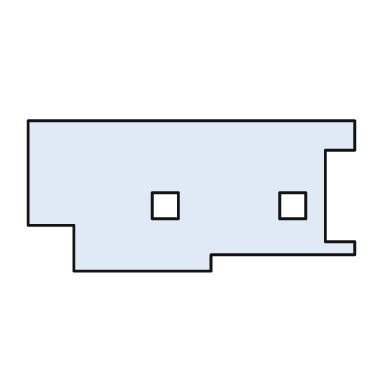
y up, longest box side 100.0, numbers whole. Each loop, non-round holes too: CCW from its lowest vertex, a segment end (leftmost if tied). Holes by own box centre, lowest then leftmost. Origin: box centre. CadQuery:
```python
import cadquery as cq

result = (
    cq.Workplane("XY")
    .moveTo(-36.0, -23.0)
    .lineTo(6.0, -23.0)
    .lineTo(6.0, -18.0)
    .lineTo(50.0, -18.0)
    .lineTo(50.0, -14.0)
    .lineTo(41.0, -14.0)
    .lineTo(41.0, 14.0)
    .lineTo(50.0, 14.0)
    .lineTo(50.0, 23.0)
    .lineTo(-50.0, 23.0)
    .lineTo(-50.0, -9.0)
    .lineTo(-36.0, -9.0)
    .close()
    .moveTo(-12.0, -7.0)
    .lineTo(-4.0, -7.0)
    .lineTo(-4.0, 1.0)
    .lineTo(-12.0, 1.0)
    .close()
    .moveTo(27.0, -7.0)
    .lineTo(35.0, -7.0)
    .lineTo(35.0, 1.0)
    .lineTo(27.0, 1.0)
    .close()
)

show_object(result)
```